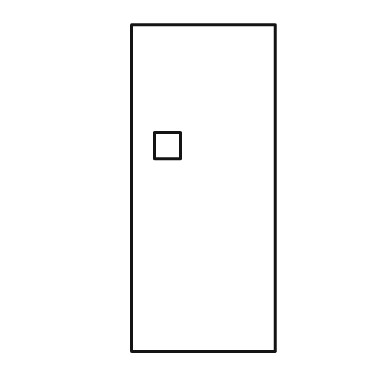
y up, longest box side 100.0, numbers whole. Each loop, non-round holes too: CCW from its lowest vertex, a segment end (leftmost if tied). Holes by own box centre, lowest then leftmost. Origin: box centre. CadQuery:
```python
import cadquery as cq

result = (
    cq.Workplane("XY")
    .moveTo(-22.0, -50.0)
    .lineTo(22.0, -50.0)
    .lineTo(22.0, 50.0)
    .lineTo(-22.0, 50.0)
    .close()
    .moveTo(-15.0, 9.0)
    .lineTo(-7.0, 9.0)
    .lineTo(-7.0, 17.0)
    .lineTo(-15.0, 17.0)
    .close()
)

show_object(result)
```